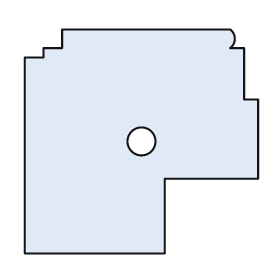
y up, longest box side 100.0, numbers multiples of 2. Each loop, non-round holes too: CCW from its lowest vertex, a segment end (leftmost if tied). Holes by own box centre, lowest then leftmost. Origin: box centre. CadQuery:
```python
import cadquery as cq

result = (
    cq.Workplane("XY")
    .moveTo(-50.0, -48.0)
    .lineTo(10.0, -48.0)
    .lineTo(10.0, -16.0)
    .lineTo(50.0, -16.0)
    .lineTo(50.0, 18.0)
    .lineTo(44.0, 18.0)
    .lineTo(44.0, 40.0)
    .lineTo(38.0, 40.0)
    .threePointArc((40.0, 44.0), (38.0, 48.0))
    .lineTo(-34.0, 48.0)
    .lineTo(-34.0, 40.0)
    .lineTo(-42.0, 40.0)
    .lineTo(-42.0, 36.0)
    .lineTo(-50.0, 36.0)
    .close()
    .moveTo(0.0, 0.0)
    .circle(6.0)
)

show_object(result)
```